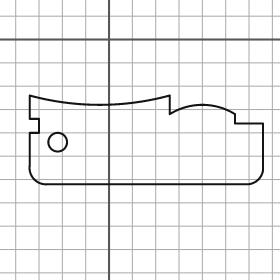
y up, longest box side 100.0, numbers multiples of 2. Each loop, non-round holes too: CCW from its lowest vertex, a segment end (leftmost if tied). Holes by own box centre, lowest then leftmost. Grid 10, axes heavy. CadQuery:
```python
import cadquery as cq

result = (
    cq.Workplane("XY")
    .moveTo(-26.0, -62.0)
    .lineTo(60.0, -62.0)
    .threePointArc((64.0, -60.0), (66.0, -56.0))
    .lineTo(66.0, -36.0)
    .lineTo(54.0, -36.0)
    .lineTo(54.0, -32.0)
    .threePointArc((40.0, -28.0), (26.0, -32.0))
    .lineTo(26.0, -24.0)
    .threePointArc((-4.0, -28.0), (-34.0, -24.0))
    .lineTo(-34.0, -34.0)
    .lineTo(-30.0, -34.0)
    .lineTo(-30.0, -40.0)
    .lineTo(-34.0, -40.0)
    .lineTo(-34.0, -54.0)
    .threePointArc((-32.0, -60.0), (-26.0, -62.0))
    .close()
    .moveTo(-22.0, -44.0)
    .circle(4.0)
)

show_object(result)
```